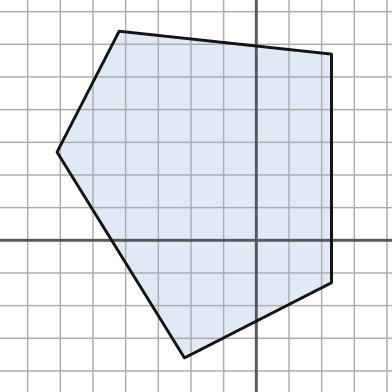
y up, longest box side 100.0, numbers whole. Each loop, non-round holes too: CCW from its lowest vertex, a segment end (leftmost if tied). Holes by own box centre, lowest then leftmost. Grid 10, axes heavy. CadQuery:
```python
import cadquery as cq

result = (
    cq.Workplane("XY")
    .moveTo(-22.0, -36.0)
    .lineTo(23.0, -13.0)
    .lineTo(23.0, 57.0)
    .lineTo(-42.0, 64.0)
    .lineTo(-61.0, 27.0)
    .close()
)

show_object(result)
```